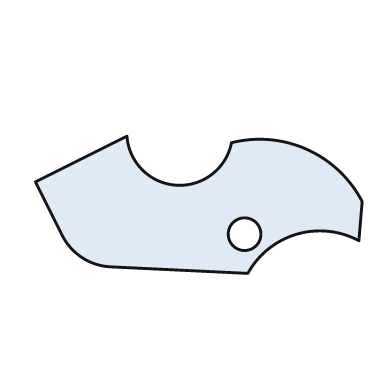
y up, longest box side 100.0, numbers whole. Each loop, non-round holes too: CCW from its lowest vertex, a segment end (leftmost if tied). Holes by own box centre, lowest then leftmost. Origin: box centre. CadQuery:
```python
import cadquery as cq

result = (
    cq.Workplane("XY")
    .moveTo(15.0, -21.0)
    .threePointArc((30.0, -9.0), (49.0, -11.0))
    .lineTo(50.0, 1.0)
    .threePointArc((33.0, 17.0), (10.0, 19.0))
    .threePointArc((-7.0, 6.0), (-22.0, 21.0))
    .lineTo(-50.0, 7.0)
    .lineTo(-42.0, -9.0)
    .threePointArc((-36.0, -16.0), (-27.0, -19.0))
    .close()
    .moveTo(14.0, -9.0)
    .circle(5.0)
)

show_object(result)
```